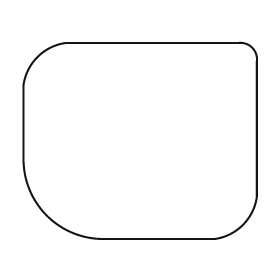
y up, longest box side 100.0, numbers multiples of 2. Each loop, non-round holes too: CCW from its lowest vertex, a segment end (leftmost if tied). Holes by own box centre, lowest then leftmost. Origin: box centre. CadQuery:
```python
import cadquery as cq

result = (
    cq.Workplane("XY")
    .moveTo(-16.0, -42.0)
    .lineTo(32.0, -42.0)
    .threePointArc((44.0, -36.0), (50.0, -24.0))
    .lineTo(50.0, 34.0)
    .threePointArc((48.0, 40.0), (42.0, 42.0))
    .lineTo(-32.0, 42.0)
    .threePointArc((-44.0, 36.0), (-50.0, 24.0))
    .lineTo(-50.0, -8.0)
    .threePointArc((-40.0, -32.0), (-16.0, -42.0))
    .close()
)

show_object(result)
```